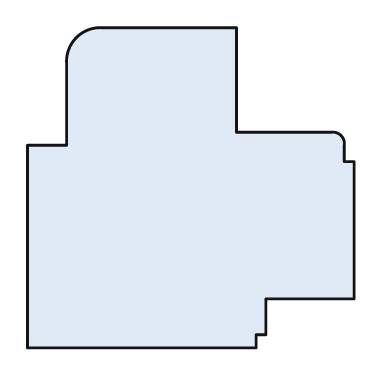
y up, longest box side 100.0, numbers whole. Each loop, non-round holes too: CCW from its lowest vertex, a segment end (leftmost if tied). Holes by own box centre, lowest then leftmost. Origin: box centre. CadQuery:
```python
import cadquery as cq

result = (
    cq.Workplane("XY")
    .moveTo(-50.0, -49.0)
    .lineTo(20.0, -49.0)
    .lineTo(20.0, -45.0)
    .lineTo(23.0, -45.0)
    .lineTo(23.0, -34.0)
    .lineTo(50.0, -34.0)
    .lineTo(50.0, 8.0)
    .lineTo(47.0, 8.0)
    .lineTo(47.0, 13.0)
    .threePointArc((46.0, 16.0), (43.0, 17.0))
    .lineTo(14.0, 17.0)
    .lineTo(14.0, 49.0)
    .lineTo(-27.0, 49.0)
    .threePointArc((-35.0, 46.0), (-38.0, 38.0))
    .lineTo(-38.0, 13.0)
    .lineTo(-50.0, 13.0)
    .close()
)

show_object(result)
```